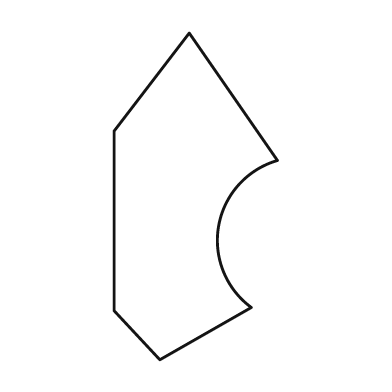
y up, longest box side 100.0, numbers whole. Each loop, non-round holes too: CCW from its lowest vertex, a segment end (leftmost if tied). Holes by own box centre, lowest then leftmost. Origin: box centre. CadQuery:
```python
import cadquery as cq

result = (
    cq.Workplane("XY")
    .moveTo(-11.0, -50.0)
    .lineTo(17.0, -34.0)
    .threePointArc((7.0, -9.0), (25.0, 11.0))
    .lineTo(-2.0, 50.0)
    .lineTo(-25.0, 20.0)
    .lineTo(-25.0, -35.0)
    .close()
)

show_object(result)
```